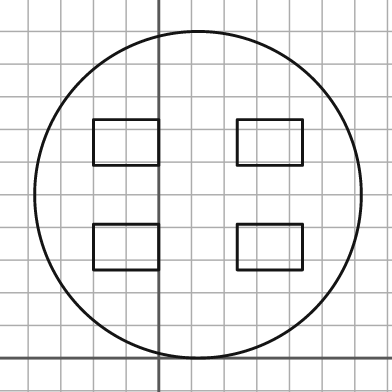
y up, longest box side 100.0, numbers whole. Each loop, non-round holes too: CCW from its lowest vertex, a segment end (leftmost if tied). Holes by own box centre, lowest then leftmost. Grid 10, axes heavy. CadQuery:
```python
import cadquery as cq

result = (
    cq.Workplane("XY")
    .moveTo(12.0, 50.0)
    .circle(50.0)
    .moveTo(-20.0, 27.0)
    .lineTo(0.0, 27.0)
    .lineTo(0.0, 41.0)
    .lineTo(-20.0, 41.0)
    .close()
    .moveTo(24.0, 27.0)
    .lineTo(44.0, 27.0)
    .lineTo(44.0, 41.0)
    .lineTo(24.0, 41.0)
    .close()
    .moveTo(-20.0, 59.0)
    .lineTo(0.0, 59.0)
    .lineTo(0.0, 73.0)
    .lineTo(-20.0, 73.0)
    .close()
    .moveTo(24.0, 59.0)
    .lineTo(44.0, 59.0)
    .lineTo(44.0, 73.0)
    .lineTo(24.0, 73.0)
    .close()
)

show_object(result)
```